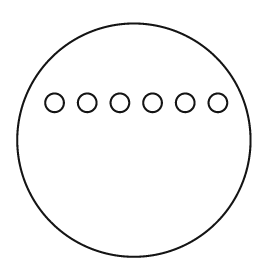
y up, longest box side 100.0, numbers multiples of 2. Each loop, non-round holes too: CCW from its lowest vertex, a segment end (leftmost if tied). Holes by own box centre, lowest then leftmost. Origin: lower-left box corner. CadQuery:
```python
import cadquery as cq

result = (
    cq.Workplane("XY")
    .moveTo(50.0, 50.0)
    .circle(50.0)
    .moveTo(16.0, 66.0)
    .circle(4.0)
    .moveTo(30.0, 66.0)
    .circle(4.0)
    .moveTo(44.0, 66.0)
    .circle(4.0)
    .moveTo(58.0, 66.0)
    .circle(4.0)
    .moveTo(72.0, 66.0)
    .circle(4.0)
    .moveTo(86.0, 66.0)
    .circle(4.0)
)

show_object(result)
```